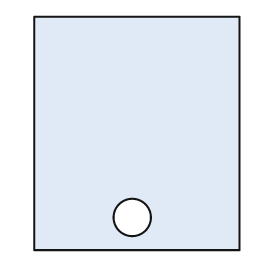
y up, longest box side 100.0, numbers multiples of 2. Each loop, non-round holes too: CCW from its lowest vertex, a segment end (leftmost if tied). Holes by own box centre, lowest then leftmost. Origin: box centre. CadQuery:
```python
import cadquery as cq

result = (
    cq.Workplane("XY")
    .moveTo(-44.0, -50.0)
    .lineTo(44.0, -50.0)
    .lineTo(44.0, 50.0)
    .lineTo(-44.0, 50.0)
    .close()
    .moveTo(-2.0, -36.0)
    .circle(8.0)
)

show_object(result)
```